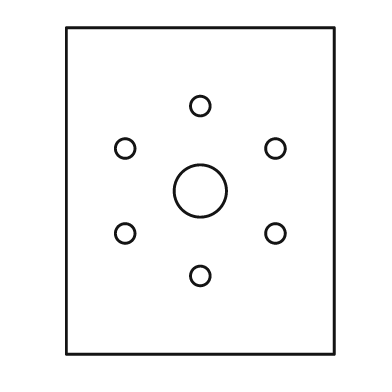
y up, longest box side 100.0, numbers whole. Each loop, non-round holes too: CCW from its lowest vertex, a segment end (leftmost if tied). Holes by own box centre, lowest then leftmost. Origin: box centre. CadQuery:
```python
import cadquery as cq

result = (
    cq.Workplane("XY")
    .moveTo(-41.0, -50.0)
    .lineTo(41.0, -50.0)
    .lineTo(41.0, 50.0)
    .lineTo(-41.0, 50.0)
    .close()
    .moveTo(0.0, -26.0)
    .circle(3.0)
    .moveTo(-23.0, -13.0)
    .circle(3.0)
    .moveTo(23.0, -13.0)
    .circle(3.0)
    .moveTo(0.0, 0.0)
    .circle(8.0)
    .moveTo(-23.0, 13.0)
    .circle(3.0)
    .moveTo(23.0, 13.0)
    .circle(3.0)
    .moveTo(0.0, 26.0)
    .circle(3.0)
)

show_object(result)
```